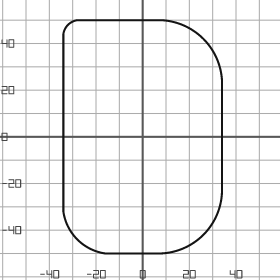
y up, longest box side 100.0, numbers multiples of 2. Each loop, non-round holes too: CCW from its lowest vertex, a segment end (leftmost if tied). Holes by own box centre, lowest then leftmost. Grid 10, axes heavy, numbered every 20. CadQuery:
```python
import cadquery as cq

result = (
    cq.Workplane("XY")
    .moveTo(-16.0, -50.0)
    .lineTo(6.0, -50.0)
    .threePointArc((26.0, -42.0), (34.0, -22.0))
    .lineTo(34.0, 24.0)
    .threePointArc((26.0, 42.0), (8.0, 50.0))
    .lineTo(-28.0, 50.0)
    .threePointArc((-32.0, 48.0), (-34.0, 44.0))
    .lineTo(-34.0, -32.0)
    .threePointArc((-28.0, -44.0), (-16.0, -50.0))
    .close()
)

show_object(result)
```